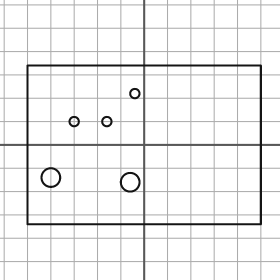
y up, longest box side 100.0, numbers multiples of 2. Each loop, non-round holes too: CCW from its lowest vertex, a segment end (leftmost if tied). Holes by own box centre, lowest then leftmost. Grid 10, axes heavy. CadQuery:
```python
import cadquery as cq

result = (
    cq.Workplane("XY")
    .moveTo(-50.0, -34.0)
    .lineTo(50.0, -34.0)
    .lineTo(50.0, 34.0)
    .lineTo(-50.0, 34.0)
    .close()
    .moveTo(-6.0, -16.0)
    .circle(4.0)
    .moveTo(-40.0, -14.0)
    .circle(4.0)
    .moveTo(-30.0, 10.0)
    .circle(2.0)
    .moveTo(-16.0, 10.0)
    .circle(2.0)
    .moveTo(-4.0, 22.0)
    .circle(2.0)
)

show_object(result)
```